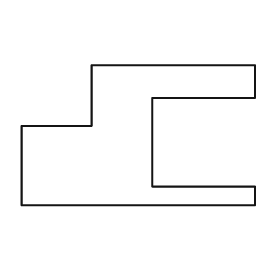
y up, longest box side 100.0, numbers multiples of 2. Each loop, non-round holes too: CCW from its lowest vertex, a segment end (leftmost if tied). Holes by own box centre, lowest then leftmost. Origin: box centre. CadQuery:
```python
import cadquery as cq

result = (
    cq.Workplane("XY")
    .moveTo(-50.0, -30.0)
    .lineTo(50.0, -30.0)
    .lineTo(50.0, -22.0)
    .lineTo(6.0, -22.0)
    .lineTo(6.0, 16.0)
    .lineTo(50.0, 16.0)
    .lineTo(50.0, 30.0)
    .lineTo(-20.0, 30.0)
    .lineTo(-20.0, 4.0)
    .lineTo(-50.0, 4.0)
    .close()
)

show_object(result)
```